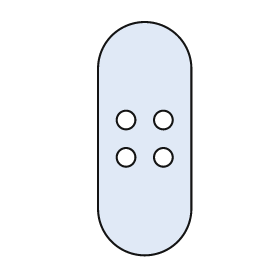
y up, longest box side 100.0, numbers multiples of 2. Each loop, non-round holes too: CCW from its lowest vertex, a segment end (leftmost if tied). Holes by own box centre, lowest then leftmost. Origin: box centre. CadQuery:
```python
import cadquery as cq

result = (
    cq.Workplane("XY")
    .moveTo(-20.0, -30.0)
    .threePointArc((0.0, -50.0), (20.0, -30.0))
    .lineTo(20.0, 30.0)
    .threePointArc((0.0, 50.0), (-20.0, 30.0))
    .close()
    .moveTo(-8.0, -8.0)
    .circle(4.0)
    .moveTo(8.0, -8.0)
    .circle(4.0)
    .moveTo(-8.0, 8.0)
    .circle(4.0)
    .moveTo(8.0, 8.0)
    .circle(4.0)
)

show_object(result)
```